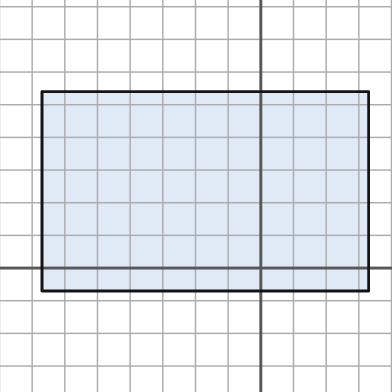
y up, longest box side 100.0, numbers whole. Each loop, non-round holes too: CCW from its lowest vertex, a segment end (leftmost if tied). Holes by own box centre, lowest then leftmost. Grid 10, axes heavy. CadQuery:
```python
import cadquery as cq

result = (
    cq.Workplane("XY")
    .moveTo(-67.0, -7.0)
    .lineTo(33.0, -7.0)
    .lineTo(33.0, 54.0)
    .lineTo(-67.0, 54.0)
    .close()
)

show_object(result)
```